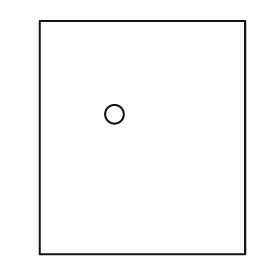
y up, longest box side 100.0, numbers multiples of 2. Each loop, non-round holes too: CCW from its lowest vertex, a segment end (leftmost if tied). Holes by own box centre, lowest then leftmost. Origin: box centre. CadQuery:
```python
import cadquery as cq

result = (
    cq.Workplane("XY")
    .moveTo(-44.0, -50.0)
    .lineTo(44.0, -50.0)
    .lineTo(44.0, 50.0)
    .lineTo(-44.0, 50.0)
    .close()
    .moveTo(-12.0, 10.0)
    .circle(4.0)
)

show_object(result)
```